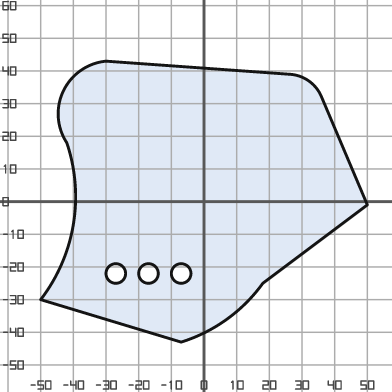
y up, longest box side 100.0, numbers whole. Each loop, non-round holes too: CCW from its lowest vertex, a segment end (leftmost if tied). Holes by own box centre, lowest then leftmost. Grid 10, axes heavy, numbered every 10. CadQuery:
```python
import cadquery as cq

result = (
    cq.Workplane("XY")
    .moveTo(-7.0, -43.0)
    .threePointArc((7.0, -36.0), (18.0, -25.0))
    .lineTo(50.0, -1.0)
    .lineTo(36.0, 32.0)
    .threePointArc((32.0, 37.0), (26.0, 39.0))
    .lineTo(-30.0, 43.0)
    .threePointArc((-43.0, 34.0), (-42.0, 18.0))
    .threePointArc((-40.0, -7.0), (-50.0, -30.0))
    .close()
    .moveTo(-27.0, -22.0)
    .circle(3.0)
    .moveTo(-17.0, -22.0)
    .circle(3.0)
    .moveTo(-7.0, -22.0)
    .circle(3.0)
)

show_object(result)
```